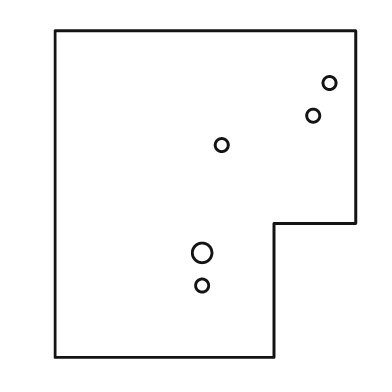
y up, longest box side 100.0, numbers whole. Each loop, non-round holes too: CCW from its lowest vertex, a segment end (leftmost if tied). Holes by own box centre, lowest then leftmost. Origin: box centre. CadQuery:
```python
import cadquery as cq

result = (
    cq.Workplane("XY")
    .moveTo(-46.0, -50.0)
    .lineTo(21.0, -50.0)
    .lineTo(21.0, -9.0)
    .lineTo(46.0, -9.0)
    .lineTo(46.0, 50.0)
    .lineTo(-46.0, 50.0)
    .close()
    .moveTo(-1.0, -28.0)
    .circle(2.0)
    .moveTo(-1.0, -18.0)
    .circle(3.0)
    .moveTo(5.0, 15.0)
    .circle(2.0)
    .moveTo(33.0, 24.0)
    .circle(2.0)
    .moveTo(38.0, 34.0)
    .circle(2.0)
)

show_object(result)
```